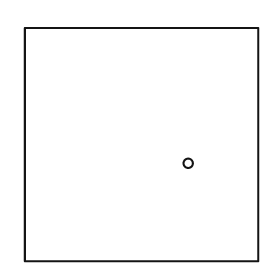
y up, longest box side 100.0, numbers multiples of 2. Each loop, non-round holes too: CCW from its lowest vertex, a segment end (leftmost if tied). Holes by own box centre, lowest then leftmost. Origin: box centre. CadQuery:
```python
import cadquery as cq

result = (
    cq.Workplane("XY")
    .moveTo(-50.0, -50.0)
    .lineTo(50.0, -50.0)
    .lineTo(50.0, 50.0)
    .lineTo(-50.0, 50.0)
    .close()
    .moveTo(20.0, -8.0)
    .circle(2.0)
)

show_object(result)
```